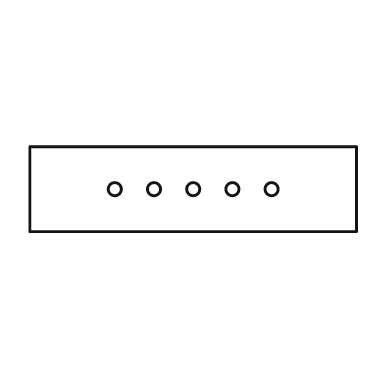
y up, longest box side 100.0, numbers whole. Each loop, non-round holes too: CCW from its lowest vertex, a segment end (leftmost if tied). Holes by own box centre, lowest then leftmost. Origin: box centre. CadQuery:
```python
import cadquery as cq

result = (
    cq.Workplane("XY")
    .moveTo(-50.0, -13.0)
    .lineTo(50.0, -13.0)
    .lineTo(50.0, 13.0)
    .lineTo(-50.0, 13.0)
    .close()
    .moveTo(-24.0, 0.0)
    .circle(2.0)
    .moveTo(-12.0, 0.0)
    .circle(2.0)
    .moveTo(0.0, 0.0)
    .circle(2.0)
    .moveTo(12.0, 0.0)
    .circle(2.0)
    .moveTo(24.0, 0.0)
    .circle(2.0)
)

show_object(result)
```